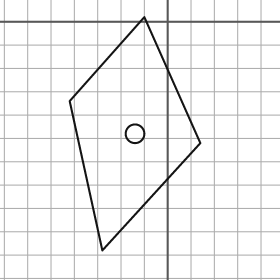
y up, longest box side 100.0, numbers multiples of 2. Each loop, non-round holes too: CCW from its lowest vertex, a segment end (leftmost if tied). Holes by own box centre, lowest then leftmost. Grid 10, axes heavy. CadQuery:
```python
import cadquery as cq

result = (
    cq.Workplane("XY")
    .moveTo(-28.0, -98.0)
    .lineTo(14.0, -52.0)
    .lineTo(-10.0, 2.0)
    .lineTo(-42.0, -34.0)
    .close()
    .moveTo(-14.0, -48.0)
    .circle(4.0)
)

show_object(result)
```